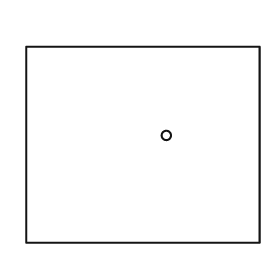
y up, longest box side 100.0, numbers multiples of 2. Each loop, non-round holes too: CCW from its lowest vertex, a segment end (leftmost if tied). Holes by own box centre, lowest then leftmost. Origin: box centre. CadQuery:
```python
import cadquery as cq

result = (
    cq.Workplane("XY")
    .moveTo(-50.0, -42.0)
    .lineTo(50.0, -42.0)
    .lineTo(50.0, 42.0)
    .lineTo(-50.0, 42.0)
    .close()
    .moveTo(10.0, 4.0)
    .circle(2.0)
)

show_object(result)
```